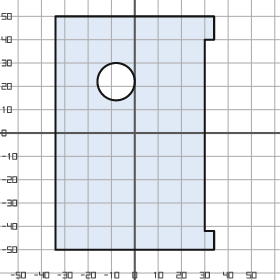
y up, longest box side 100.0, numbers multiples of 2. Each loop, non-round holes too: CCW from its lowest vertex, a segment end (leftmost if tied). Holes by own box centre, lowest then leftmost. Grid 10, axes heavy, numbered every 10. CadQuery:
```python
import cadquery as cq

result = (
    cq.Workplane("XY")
    .moveTo(-34.0, -50.0)
    .lineTo(34.0, -50.0)
    .lineTo(34.0, -42.0)
    .lineTo(30.0, -42.0)
    .lineTo(30.0, 40.0)
    .lineTo(34.0, 40.0)
    .lineTo(34.0, 50.0)
    .lineTo(-34.0, 50.0)
    .close()
    .moveTo(-8.0, 22.0)
    .circle(8.0)
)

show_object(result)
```